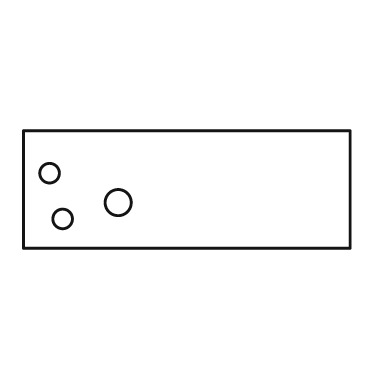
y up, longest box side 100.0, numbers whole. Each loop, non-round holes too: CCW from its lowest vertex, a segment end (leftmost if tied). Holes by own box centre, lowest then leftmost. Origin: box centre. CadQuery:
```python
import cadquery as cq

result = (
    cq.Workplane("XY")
    .moveTo(-50.0, -18.0)
    .lineTo(50.0, -18.0)
    .lineTo(50.0, 18.0)
    .lineTo(-50.0, 18.0)
    .close()
    .moveTo(-38.0, -9.0)
    .circle(3.0)
    .moveTo(-21.0, -4.0)
    .circle(4.0)
    .moveTo(-42.0, 5.0)
    .circle(3.0)
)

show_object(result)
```